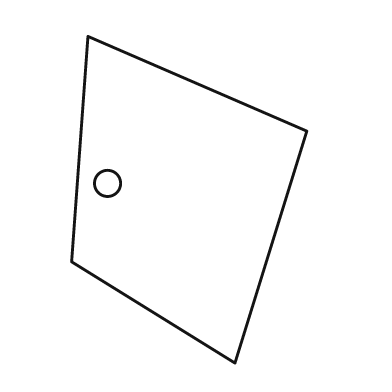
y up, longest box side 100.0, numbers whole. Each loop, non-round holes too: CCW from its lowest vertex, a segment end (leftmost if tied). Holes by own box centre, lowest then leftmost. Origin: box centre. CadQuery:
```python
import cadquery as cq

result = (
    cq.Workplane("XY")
    .moveTo(14.0, -50.0)
    .lineTo(36.0, 21.0)
    .lineTo(-31.0, 50.0)
    .lineTo(-36.0, -19.0)
    .close()
    .moveTo(-25.0, 5.0)
    .circle(4.0)
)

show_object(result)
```